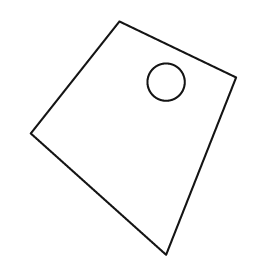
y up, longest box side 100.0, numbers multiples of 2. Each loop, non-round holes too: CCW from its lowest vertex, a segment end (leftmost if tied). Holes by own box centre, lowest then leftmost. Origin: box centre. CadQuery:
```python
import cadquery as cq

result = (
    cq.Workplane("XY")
    .moveTo(14.0, -50.0)
    .lineTo(44.0, 26.0)
    .lineTo(-6.0, 50.0)
    .lineTo(-44.0, 2.0)
    .close()
    .moveTo(14.0, 24.0)
    .circle(8.0)
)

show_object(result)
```